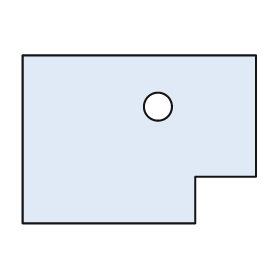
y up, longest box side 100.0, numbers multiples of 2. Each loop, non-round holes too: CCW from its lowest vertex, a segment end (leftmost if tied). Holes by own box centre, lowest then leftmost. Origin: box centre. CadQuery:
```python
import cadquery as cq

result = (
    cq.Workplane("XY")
    .moveTo(-50.0, -36.0)
    .lineTo(24.0, -36.0)
    .lineTo(24.0, -16.0)
    .lineTo(50.0, -16.0)
    .lineTo(50.0, 36.0)
    .lineTo(-50.0, 36.0)
    .close()
    .moveTo(8.0, 14.0)
    .circle(6.0)
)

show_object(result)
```